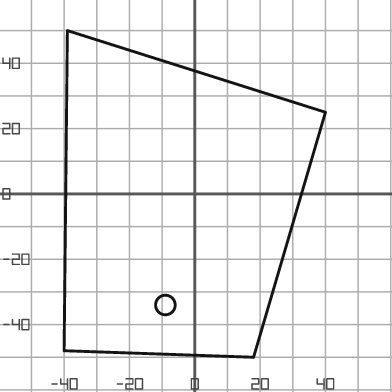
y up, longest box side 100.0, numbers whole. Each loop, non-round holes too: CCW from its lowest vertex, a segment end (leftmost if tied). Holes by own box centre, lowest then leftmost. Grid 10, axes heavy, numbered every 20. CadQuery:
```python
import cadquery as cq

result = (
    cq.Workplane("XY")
    .moveTo(18.0, -50.0)
    .lineTo(40.0, 25.0)
    .lineTo(-39.0, 50.0)
    .lineTo(-40.0, -48.0)
    .close()
    .moveTo(-9.0, -34.0)
    .circle(3.0)
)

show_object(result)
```